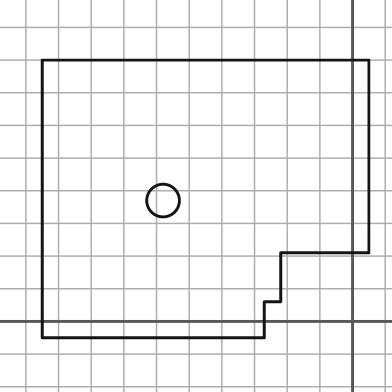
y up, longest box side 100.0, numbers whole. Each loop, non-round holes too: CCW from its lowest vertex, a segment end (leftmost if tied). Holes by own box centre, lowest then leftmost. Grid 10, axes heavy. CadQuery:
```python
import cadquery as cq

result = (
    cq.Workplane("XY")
    .moveTo(-95.0, -5.0)
    .lineTo(-27.0, -5.0)
    .lineTo(-27.0, 6.0)
    .lineTo(-22.0, 6.0)
    .lineTo(-22.0, 21.0)
    .lineTo(5.0, 21.0)
    .lineTo(5.0, 80.0)
    .lineTo(-95.0, 80.0)
    .close()
    .moveTo(-58.0, 37.0)
    .circle(5.0)
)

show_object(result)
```